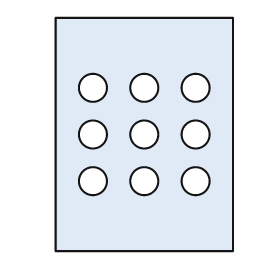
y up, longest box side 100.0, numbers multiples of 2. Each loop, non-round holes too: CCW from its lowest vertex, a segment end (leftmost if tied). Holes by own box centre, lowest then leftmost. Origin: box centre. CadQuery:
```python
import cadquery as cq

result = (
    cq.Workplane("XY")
    .moveTo(-38.0, -50.0)
    .lineTo(38.0, -50.0)
    .lineTo(38.0, 50.0)
    .lineTo(-38.0, 50.0)
    .close()
    .moveTo(-22.0, -20.0)
    .circle(6.0)
    .moveTo(0.0, -20.0)
    .circle(6.0)
    .moveTo(22.0, -20.0)
    .circle(6.0)
    .moveTo(-22.0, 0.0)
    .circle(6.0)
    .moveTo(0.0, 0.0)
    .circle(6.0)
    .moveTo(22.0, 0.0)
    .circle(6.0)
    .moveTo(-22.0, 20.0)
    .circle(6.0)
    .moveTo(0.0, 20.0)
    .circle(6.0)
    .moveTo(22.0, 20.0)
    .circle(6.0)
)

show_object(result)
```